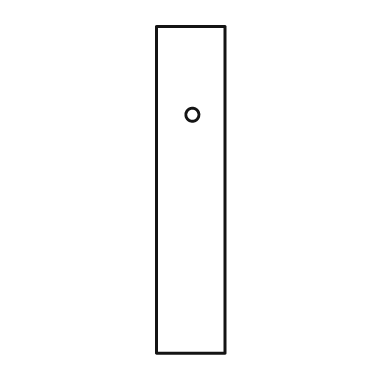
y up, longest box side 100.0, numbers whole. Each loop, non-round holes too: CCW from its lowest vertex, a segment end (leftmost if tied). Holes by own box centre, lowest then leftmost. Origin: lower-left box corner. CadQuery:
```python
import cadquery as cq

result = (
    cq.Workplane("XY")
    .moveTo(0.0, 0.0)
    .lineTo(21.0, 0.0)
    .lineTo(21.0, 100.0)
    .lineTo(0.0, 100.0)
    .close()
    .moveTo(11.0, 73.0)
    .circle(2.0)
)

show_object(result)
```